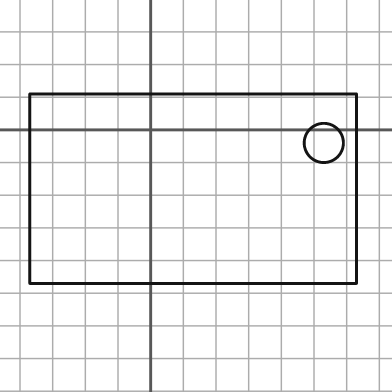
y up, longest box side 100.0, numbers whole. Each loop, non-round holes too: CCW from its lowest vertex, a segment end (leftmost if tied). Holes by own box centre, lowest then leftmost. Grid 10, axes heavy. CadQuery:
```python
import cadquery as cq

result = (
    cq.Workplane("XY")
    .moveTo(-37.0, -47.0)
    .lineTo(63.0, -47.0)
    .lineTo(63.0, 11.0)
    .lineTo(-37.0, 11.0)
    .close()
    .moveTo(53.0, -4.0)
    .circle(6.0)
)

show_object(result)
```